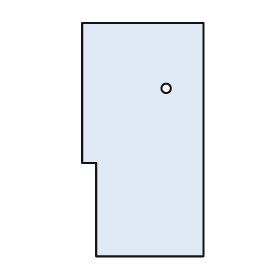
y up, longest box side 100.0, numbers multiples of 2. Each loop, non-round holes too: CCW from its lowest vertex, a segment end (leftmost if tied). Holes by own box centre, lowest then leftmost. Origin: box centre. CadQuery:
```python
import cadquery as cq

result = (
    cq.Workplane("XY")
    .moveTo(-20.0, -50.0)
    .lineTo(26.0, -50.0)
    .lineTo(26.0, 50.0)
    .lineTo(-26.0, 50.0)
    .lineTo(-26.0, -10.0)
    .lineTo(-20.0, -10.0)
    .close()
    .moveTo(10.0, 22.0)
    .circle(2.0)
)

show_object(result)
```